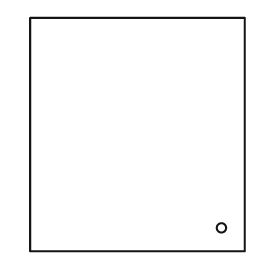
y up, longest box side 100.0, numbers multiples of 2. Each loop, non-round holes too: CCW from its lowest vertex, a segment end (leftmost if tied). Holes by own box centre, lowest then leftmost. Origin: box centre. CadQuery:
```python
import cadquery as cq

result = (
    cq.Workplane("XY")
    .moveTo(-46.0, -50.0)
    .lineTo(46.0, -50.0)
    .lineTo(46.0, 50.0)
    .lineTo(-46.0, 50.0)
    .close()
    .moveTo(36.0, -40.0)
    .circle(2.0)
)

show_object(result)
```